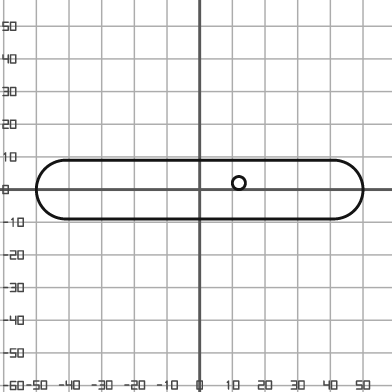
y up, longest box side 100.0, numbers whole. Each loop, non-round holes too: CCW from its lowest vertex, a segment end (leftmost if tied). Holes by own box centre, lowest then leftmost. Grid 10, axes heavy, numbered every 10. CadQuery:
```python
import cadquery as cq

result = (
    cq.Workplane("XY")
    .moveTo(-41.0, -9.0)
    .lineTo(41.0, -9.0)
    .threePointArc((50.0, 0.0), (41.0, 9.0))
    .lineTo(-41.0, 9.0)
    .threePointArc((-50.0, 0.0), (-41.0, -9.0))
    .close()
    .moveTo(12.0, 2.0)
    .circle(2.0)
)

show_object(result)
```